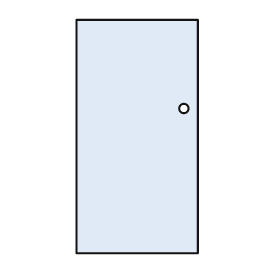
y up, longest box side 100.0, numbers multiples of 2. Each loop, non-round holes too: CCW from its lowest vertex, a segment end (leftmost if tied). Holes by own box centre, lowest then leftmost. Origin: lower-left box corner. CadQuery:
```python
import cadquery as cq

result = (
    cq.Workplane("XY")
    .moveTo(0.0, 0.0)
    .lineTo(52.0, 0.0)
    .lineTo(52.0, 100.0)
    .lineTo(0.0, 100.0)
    .close()
    .moveTo(46.0, 62.0)
    .circle(2.0)
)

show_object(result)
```